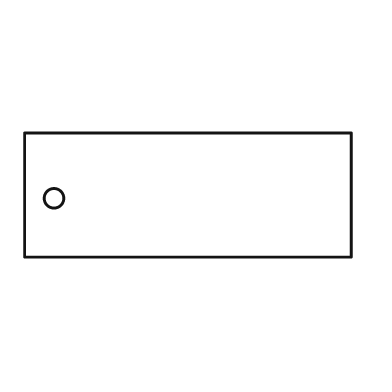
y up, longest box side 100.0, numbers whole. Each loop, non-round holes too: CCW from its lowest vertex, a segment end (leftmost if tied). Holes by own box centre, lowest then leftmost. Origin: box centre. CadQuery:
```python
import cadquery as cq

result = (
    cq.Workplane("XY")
    .moveTo(-50.0, -19.0)
    .lineTo(50.0, -19.0)
    .lineTo(50.0, 19.0)
    .lineTo(-50.0, 19.0)
    .close()
    .moveTo(-41.0, -1.0)
    .circle(3.0)
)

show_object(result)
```